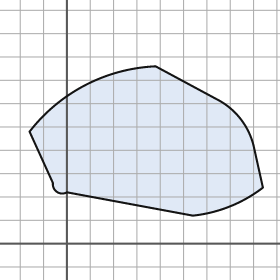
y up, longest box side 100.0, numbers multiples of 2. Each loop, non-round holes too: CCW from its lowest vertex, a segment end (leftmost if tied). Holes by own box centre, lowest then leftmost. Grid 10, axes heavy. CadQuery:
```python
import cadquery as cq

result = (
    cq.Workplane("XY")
    .moveTo(54.0, 12.0)
    .threePointArc((70.0, 16.0), (84.0, 24.0))
    .lineTo(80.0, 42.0)
    .threePointArc((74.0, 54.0), (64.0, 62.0))
    .lineTo(38.0, 76.0)
    .threePointArc((8.0, 68.0), (-16.0, 48.0))
    .lineTo(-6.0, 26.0)
    .threePointArc((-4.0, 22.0), (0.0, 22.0))
    .close()
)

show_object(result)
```